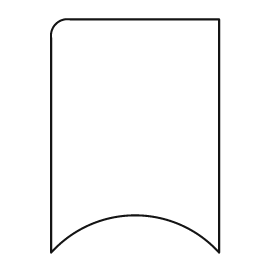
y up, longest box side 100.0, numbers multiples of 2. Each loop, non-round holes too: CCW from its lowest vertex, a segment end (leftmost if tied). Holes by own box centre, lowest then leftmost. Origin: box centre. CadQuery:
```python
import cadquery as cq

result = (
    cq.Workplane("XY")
    .moveTo(-36.0, -50.0)
    .threePointArc((0.0, -34.0), (36.0, -50.0))
    .lineTo(36.0, 50.0)
    .lineTo(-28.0, 50.0)
    .threePointArc((-34.0, 48.0), (-36.0, 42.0))
    .close()
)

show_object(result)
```